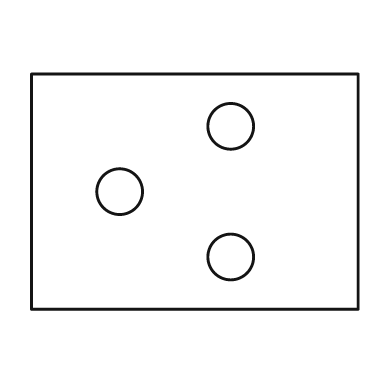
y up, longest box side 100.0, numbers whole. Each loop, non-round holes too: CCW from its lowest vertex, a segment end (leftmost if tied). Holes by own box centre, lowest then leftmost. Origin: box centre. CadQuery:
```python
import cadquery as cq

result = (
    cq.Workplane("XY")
    .moveTo(-50.0, -36.0)
    .lineTo(50.0, -36.0)
    .lineTo(50.0, 36.0)
    .lineTo(-50.0, 36.0)
    .close()
    .moveTo(11.0, -20.0)
    .circle(7.0)
    .moveTo(-23.0, 0.0)
    .circle(7.0)
    .moveTo(11.0, 20.0)
    .circle(7.0)
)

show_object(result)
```